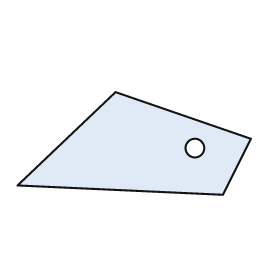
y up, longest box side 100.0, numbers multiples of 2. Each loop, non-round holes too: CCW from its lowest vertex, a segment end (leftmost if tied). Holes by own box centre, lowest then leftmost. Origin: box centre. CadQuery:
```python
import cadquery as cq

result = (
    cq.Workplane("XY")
    .moveTo(38.0, -22.0)
    .lineTo(50.0, 2.0)
    .lineTo(-8.0, 22.0)
    .lineTo(-50.0, -18.0)
    .close()
    .moveTo(26.0, -2.0)
    .circle(4.0)
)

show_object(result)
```